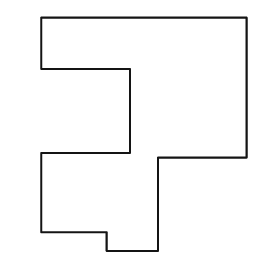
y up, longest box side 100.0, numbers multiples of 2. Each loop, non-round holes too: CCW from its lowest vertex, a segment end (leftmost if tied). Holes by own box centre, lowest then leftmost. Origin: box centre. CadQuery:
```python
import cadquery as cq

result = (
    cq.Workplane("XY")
    .moveTo(-16.0, -50.0)
    .lineTo(6.0, -50.0)
    .lineTo(6.0, -10.0)
    .lineTo(44.0, -10.0)
    .lineTo(44.0, 50.0)
    .lineTo(-44.0, 50.0)
    .lineTo(-44.0, 28.0)
    .lineTo(-6.0, 28.0)
    .lineTo(-6.0, -8.0)
    .lineTo(-44.0, -8.0)
    .lineTo(-44.0, -42.0)
    .lineTo(-16.0, -42.0)
    .close()
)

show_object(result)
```